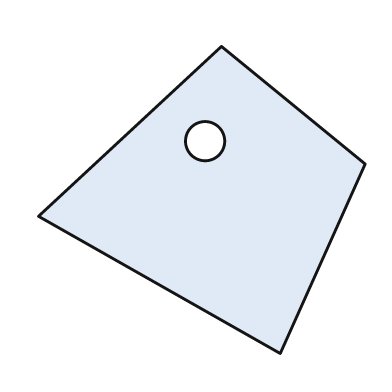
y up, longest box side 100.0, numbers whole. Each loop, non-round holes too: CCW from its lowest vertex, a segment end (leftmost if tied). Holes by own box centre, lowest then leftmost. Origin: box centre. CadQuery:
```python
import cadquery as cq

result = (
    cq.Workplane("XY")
    .moveTo(24.0, -47.0)
    .lineTo(50.0, 11.0)
    .lineTo(6.0, 47.0)
    .lineTo(-50.0, -5.0)
    .close()
    .moveTo(1.0, 18.0)
    .circle(6.0)
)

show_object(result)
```